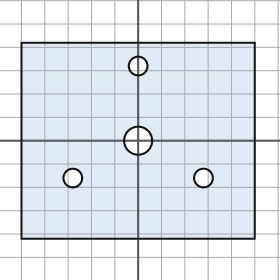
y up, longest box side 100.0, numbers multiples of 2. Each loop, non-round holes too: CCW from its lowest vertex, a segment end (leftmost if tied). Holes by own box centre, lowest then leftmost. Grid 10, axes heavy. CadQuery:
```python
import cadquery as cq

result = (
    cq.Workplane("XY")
    .moveTo(-50.0, -42.0)
    .lineTo(50.0, -42.0)
    .lineTo(50.0, 42.0)
    .lineTo(-50.0, 42.0)
    .close()
    .moveTo(-28.0, -16.0)
    .circle(4.0)
    .moveTo(28.0, -16.0)
    .circle(4.0)
    .moveTo(0.0, 0.0)
    .circle(6.0)
    .moveTo(0.0, 32.0)
    .circle(4.0)
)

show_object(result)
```